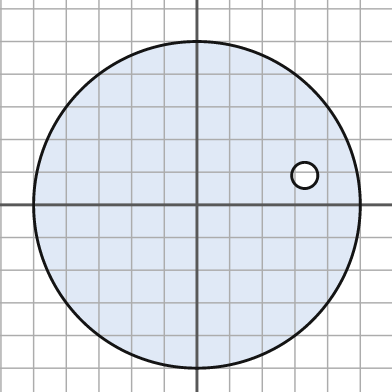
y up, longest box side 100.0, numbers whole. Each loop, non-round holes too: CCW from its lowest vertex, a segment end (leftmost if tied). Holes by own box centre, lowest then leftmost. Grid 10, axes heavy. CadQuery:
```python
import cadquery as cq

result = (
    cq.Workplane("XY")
    .moveTo(0.0, 0.0)
    .circle(50.0)
    .moveTo(33.0, 9.0)
    .circle(4.0)
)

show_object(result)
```